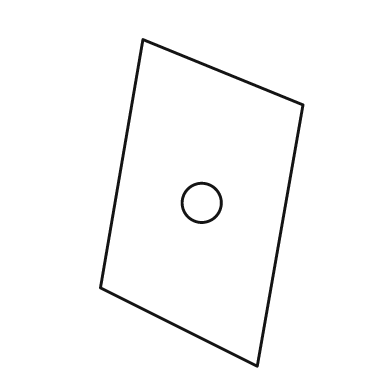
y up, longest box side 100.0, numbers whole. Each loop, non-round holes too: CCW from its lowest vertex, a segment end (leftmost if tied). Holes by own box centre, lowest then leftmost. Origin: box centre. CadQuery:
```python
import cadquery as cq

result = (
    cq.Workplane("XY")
    .moveTo(17.0, -50.0)
    .lineTo(31.0, 30.0)
    .lineTo(-18.0, 50.0)
    .lineTo(-31.0, -26.0)
    .close()
    .moveTo(0.0, 0.0)
    .circle(6.0)
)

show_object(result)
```